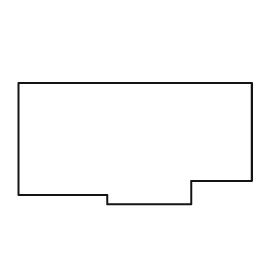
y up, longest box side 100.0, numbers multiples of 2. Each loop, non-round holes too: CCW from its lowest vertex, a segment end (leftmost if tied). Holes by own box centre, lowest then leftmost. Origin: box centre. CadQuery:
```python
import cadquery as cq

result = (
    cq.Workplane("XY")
    .moveTo(-12.0, -26.0)
    .lineTo(24.0, -26.0)
    .lineTo(24.0, -16.0)
    .lineTo(50.0, -16.0)
    .lineTo(50.0, 26.0)
    .lineTo(-50.0, 26.0)
    .lineTo(-50.0, -22.0)
    .lineTo(-12.0, -22.0)
    .close()
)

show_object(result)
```